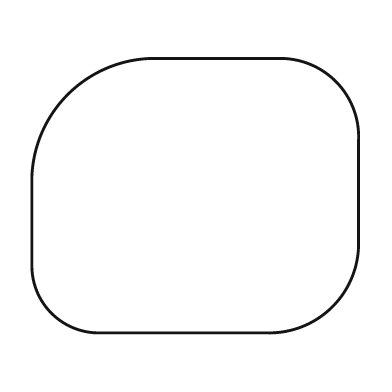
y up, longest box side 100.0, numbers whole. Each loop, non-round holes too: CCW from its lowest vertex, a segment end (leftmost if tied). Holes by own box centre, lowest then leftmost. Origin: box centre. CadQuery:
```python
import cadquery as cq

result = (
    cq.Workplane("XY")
    .moveTo(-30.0, -42.0)
    .lineTo(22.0, -42.0)
    .threePointArc((42.0, -34.0), (50.0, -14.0))
    .lineTo(50.0, 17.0)
    .threePointArc((43.0, 35.0), (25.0, 42.0))
    .lineTo(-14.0, 42.0)
    .threePointArc((-39.0, 31.0), (-50.0, 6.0))
    .lineTo(-50.0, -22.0)
    .threePointArc((-44.0, -36.0), (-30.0, -42.0))
    .close()
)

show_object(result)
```